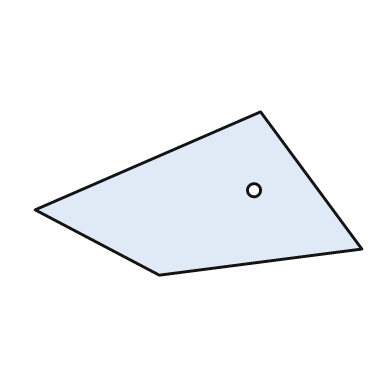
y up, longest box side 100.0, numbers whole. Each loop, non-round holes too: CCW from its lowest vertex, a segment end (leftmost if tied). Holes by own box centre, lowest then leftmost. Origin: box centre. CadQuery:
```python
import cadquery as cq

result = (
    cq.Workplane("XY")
    .moveTo(-12.0, -25.0)
    .lineTo(50.0, -17.0)
    .lineTo(19.0, 25.0)
    .lineTo(-50.0, -5.0)
    .close()
    .moveTo(17.0, 1.0)
    .circle(2.0)
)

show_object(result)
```